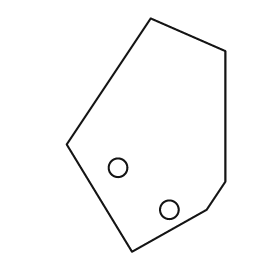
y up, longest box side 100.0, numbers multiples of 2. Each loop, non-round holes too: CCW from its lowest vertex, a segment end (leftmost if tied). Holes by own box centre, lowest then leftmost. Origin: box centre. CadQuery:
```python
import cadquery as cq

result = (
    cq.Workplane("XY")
    .moveTo(-6.0, -50.0)
    .lineTo(26.0, -32.0)
    .lineTo(34.0, -20.0)
    .lineTo(34.0, 36.0)
    .lineTo(2.0, 50.0)
    .lineTo(-34.0, -4.0)
    .close()
    .moveTo(10.0, -32.0)
    .circle(4.0)
    .moveTo(-12.0, -14.0)
    .circle(4.0)
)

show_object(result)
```